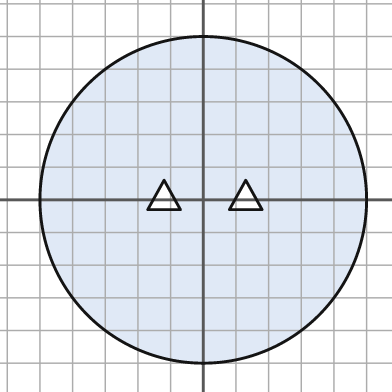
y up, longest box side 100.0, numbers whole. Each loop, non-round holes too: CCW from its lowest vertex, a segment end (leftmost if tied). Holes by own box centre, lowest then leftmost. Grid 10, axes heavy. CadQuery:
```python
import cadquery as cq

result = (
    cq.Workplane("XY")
    .moveTo(0.0, 0.0)
    .circle(50.0)
    .moveTo(-17.0, -3.0)
    .lineTo(-7.0, -3.0)
    .lineTo(-12.0, 6.0)
    .close()
    .moveTo(8.0, -3.0)
    .lineTo(18.0, -3.0)
    .lineTo(13.0, 6.0)
    .close()
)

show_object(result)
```